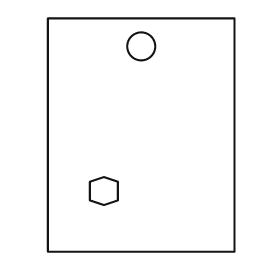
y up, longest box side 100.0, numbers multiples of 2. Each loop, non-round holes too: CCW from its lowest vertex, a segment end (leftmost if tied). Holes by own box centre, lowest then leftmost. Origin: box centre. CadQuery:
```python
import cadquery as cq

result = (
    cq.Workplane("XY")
    .moveTo(-40.0, -50.0)
    .lineTo(40.0, -50.0)
    .lineTo(40.0, 50.0)
    .lineTo(-40.0, 50.0)
    .close()
    .moveTo(-16.0, -30.0)
    .lineTo(-10.0, -28.0)
    .lineTo(-10.0, -20.0)
    .lineTo(-16.0, -18.0)
    .lineTo(-22.0, -20.0)
    .lineTo(-22.0, -28.0)
    .close()
    .moveTo(0.0, 38.0)
    .circle(6.0)
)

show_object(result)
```